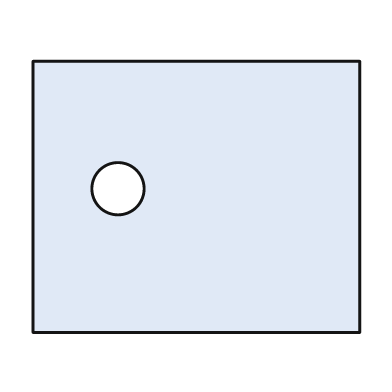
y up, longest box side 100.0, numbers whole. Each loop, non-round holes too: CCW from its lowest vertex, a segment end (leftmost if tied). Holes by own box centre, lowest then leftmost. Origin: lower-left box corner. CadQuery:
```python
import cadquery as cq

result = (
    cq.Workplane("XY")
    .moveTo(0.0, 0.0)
    .lineTo(100.0, 0.0)
    .lineTo(100.0, 83.0)
    .lineTo(0.0, 83.0)
    .close()
    .moveTo(26.0, 44.0)
    .circle(8.0)
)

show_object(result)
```